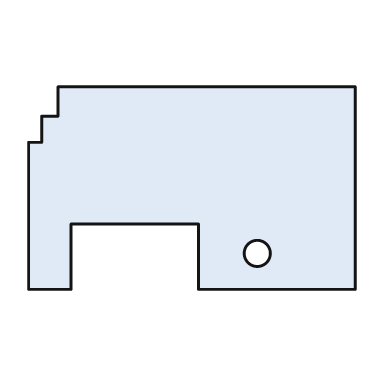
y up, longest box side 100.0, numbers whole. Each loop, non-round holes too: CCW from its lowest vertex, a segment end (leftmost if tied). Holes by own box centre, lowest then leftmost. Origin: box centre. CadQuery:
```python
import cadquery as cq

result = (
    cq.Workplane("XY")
    .moveTo(-50.0, -31.0)
    .lineTo(-37.0, -31.0)
    .lineTo(-37.0, -11.0)
    .lineTo(2.0, -11.0)
    .lineTo(2.0, -31.0)
    .lineTo(50.0, -31.0)
    .lineTo(50.0, 31.0)
    .lineTo(-41.0, 31.0)
    .lineTo(-41.0, 22.0)
    .lineTo(-46.0, 22.0)
    .lineTo(-46.0, 14.0)
    .lineTo(-50.0, 14.0)
    .close()
    .moveTo(20.0, -20.0)
    .circle(4.0)
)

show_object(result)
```